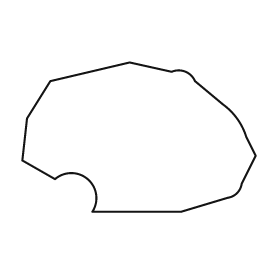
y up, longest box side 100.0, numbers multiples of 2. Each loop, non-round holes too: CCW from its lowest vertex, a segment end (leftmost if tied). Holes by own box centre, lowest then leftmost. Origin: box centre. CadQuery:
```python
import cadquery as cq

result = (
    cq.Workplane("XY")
    .moveTo(-20.0, -32.0)
    .lineTo(18.0, -32.0)
    .lineTo(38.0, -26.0)
    .threePointArc((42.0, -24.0), (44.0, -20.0))
    .lineTo(50.0, -8.0)
    .lineTo(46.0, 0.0)
    .threePointArc((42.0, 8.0), (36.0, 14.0))
    .lineTo(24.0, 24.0)
    .threePointArc((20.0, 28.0), (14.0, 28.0))
    .lineTo(-4.0, 32.0)
    .lineTo(-38.0, 24.0)
    .lineTo(-48.0, 8.0)
    .lineTo(-50.0, -10.0)
    .lineTo(-36.0, -18.0)
    .threePointArc((-22.0, -18.0), (-20.0, -32.0))
    .close()
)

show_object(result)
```